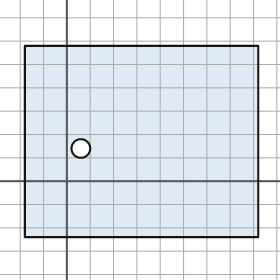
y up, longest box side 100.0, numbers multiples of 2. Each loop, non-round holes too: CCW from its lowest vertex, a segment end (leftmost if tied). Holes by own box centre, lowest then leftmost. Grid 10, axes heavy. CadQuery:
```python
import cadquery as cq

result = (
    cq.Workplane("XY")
    .moveTo(-18.0, -24.0)
    .lineTo(82.0, -24.0)
    .lineTo(82.0, 58.0)
    .lineTo(-18.0, 58.0)
    .close()
    .moveTo(6.0, 14.0)
    .circle(4.0)
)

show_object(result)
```